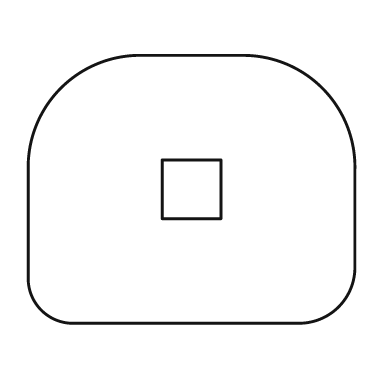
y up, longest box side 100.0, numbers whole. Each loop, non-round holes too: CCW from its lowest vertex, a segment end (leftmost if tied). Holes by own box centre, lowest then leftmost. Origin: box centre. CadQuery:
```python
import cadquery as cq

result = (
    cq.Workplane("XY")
    .moveTo(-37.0, -41.0)
    .lineTo(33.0, -41.0)
    .threePointArc((45.0, -36.0), (50.0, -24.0))
    .lineTo(50.0, 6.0)
    .threePointArc((40.0, 31.0), (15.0, 41.0))
    .lineTo(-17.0, 41.0)
    .threePointArc((-40.0, 31.0), (-50.0, 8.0))
    .lineTo(-50.0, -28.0)
    .threePointArc((-46.0, -37.0), (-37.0, -41.0))
    .close()
    .moveTo(-9.0, -9.0)
    .lineTo(9.0, -9.0)
    .lineTo(9.0, 9.0)
    .lineTo(-9.0, 9.0)
    .close()
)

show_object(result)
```